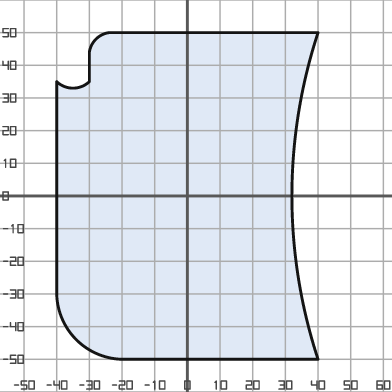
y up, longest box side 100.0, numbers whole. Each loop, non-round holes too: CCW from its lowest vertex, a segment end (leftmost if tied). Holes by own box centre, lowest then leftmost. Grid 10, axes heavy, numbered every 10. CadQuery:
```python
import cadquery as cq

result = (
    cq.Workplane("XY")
    .moveTo(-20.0, -50.0)
    .lineTo(40.0, -50.0)
    .threePointArc((32.0, 0.0), (40.0, 50.0))
    .lineTo(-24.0, 50.0)
    .threePointArc((-28.0, 48.0), (-30.0, 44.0))
    .lineTo(-30.0, 35.0)
    .threePointArc((-35.0, 33.0), (-40.0, 35.0))
    .lineTo(-40.0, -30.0)
    .threePointArc((-34.0, -44.0), (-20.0, -50.0))
    .close()
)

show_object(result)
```